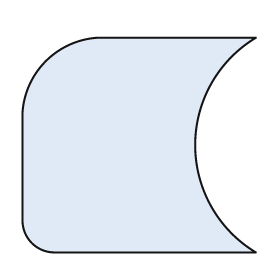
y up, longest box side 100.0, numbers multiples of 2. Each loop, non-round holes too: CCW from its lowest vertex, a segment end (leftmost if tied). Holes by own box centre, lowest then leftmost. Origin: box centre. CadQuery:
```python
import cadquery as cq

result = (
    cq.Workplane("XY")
    .moveTo(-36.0, -46.0)
    .lineTo(50.0, -46.0)
    .threePointArc((24.0, 0.0), (50.0, 46.0))
    .lineTo(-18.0, 46.0)
    .threePointArc((-40.0, 36.0), (-50.0, 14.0))
    .lineTo(-50.0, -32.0)
    .threePointArc((-46.0, -42.0), (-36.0, -46.0))
    .close()
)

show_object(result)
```